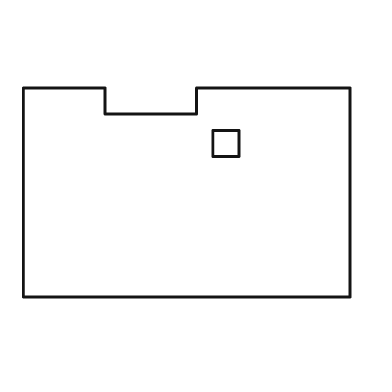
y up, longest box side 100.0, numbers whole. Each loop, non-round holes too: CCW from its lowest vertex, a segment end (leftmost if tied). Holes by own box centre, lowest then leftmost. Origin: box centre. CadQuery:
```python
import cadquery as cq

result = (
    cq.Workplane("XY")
    .moveTo(-50.0, -32.0)
    .lineTo(50.0, -32.0)
    .lineTo(50.0, 32.0)
    .lineTo(3.0, 32.0)
    .lineTo(3.0, 24.0)
    .lineTo(-25.0, 24.0)
    .lineTo(-25.0, 32.0)
    .lineTo(-50.0, 32.0)
    .close()
    .moveTo(8.0, 11.0)
    .lineTo(16.0, 11.0)
    .lineTo(16.0, 19.0)
    .lineTo(8.0, 19.0)
    .close()
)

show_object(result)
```